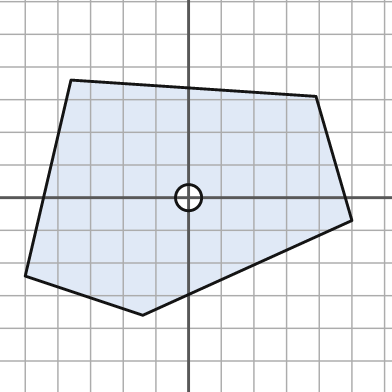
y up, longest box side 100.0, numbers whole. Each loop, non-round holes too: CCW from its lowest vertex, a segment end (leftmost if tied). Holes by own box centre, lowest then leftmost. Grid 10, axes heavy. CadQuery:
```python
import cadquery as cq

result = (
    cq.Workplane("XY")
    .moveTo(-14.0, -36.0)
    .lineTo(50.0, -7.0)
    .lineTo(39.0, 31.0)
    .lineTo(-36.0, 36.0)
    .lineTo(-50.0, -24.0)
    .close()
    .moveTo(0.0, 0.0)
    .circle(4.0)
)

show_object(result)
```